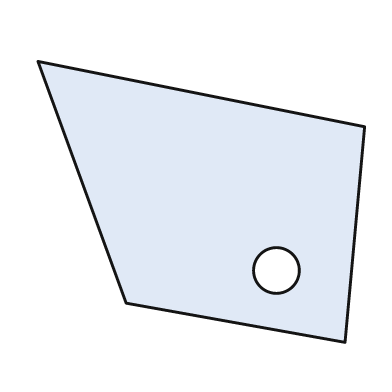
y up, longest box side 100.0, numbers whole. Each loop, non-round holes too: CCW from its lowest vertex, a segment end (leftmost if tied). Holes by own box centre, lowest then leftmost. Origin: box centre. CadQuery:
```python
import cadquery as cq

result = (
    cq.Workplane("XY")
    .moveTo(44.0, -43.0)
    .lineTo(50.0, 23.0)
    .lineTo(-50.0, 43.0)
    .lineTo(-23.0, -31.0)
    .close()
    .moveTo(23.0, -21.0)
    .circle(7.0)
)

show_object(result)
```